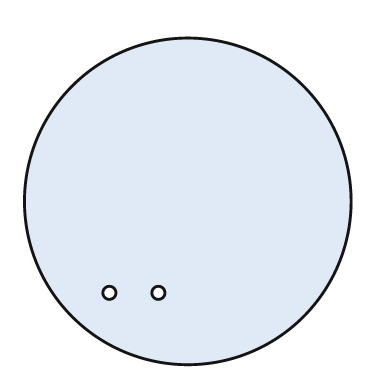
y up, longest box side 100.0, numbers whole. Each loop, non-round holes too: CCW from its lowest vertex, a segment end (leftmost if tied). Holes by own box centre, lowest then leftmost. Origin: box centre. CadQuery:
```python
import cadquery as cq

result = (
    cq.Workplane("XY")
    .moveTo(0.0, 0.0)
    .circle(50.0)
    .moveTo(-24.0, -28.0)
    .circle(2.0)
    .moveTo(-9.0, -28.0)
    .circle(2.0)
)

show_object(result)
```